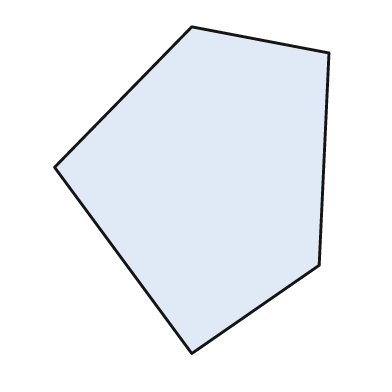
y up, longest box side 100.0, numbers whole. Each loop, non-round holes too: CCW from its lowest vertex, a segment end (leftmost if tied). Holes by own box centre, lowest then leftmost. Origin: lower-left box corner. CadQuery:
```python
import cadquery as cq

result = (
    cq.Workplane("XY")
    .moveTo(42.0, 0.0)
    .lineTo(81.0, 27.0)
    .lineTo(84.0, 92.0)
    .lineTo(42.0, 100.0)
    .lineTo(0.0, 57.0)
    .close()
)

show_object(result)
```